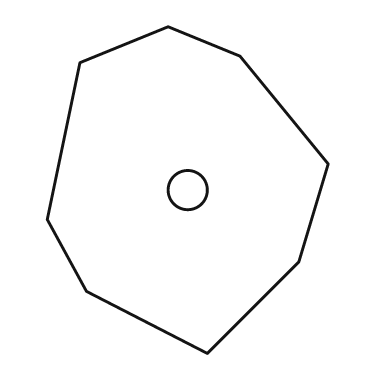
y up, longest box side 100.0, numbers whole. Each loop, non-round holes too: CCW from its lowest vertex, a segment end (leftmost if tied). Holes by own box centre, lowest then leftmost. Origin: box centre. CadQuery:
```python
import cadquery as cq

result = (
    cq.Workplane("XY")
    .moveTo(6.0, -50.0)
    .lineTo(34.0, -22.0)
    .lineTo(43.0, 8.0)
    .lineTo(16.0, 41.0)
    .lineTo(-6.0, 50.0)
    .lineTo(-33.0, 39.0)
    .lineTo(-43.0, -9.0)
    .lineTo(-31.0, -31.0)
    .close()
    .moveTo(0.0, 0.0)
    .circle(6.0)
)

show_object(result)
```